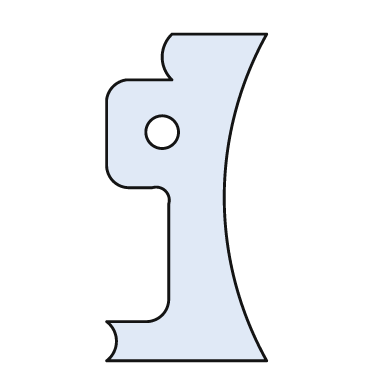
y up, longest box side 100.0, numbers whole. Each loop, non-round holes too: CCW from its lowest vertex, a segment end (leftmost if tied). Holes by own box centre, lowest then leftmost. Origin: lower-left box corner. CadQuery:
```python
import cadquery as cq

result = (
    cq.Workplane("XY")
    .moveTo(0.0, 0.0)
    .lineTo(49.0, 0.0)
    .threePointArc((36.0, 50.0), (49.0, 100.0))
    .lineTo(20.0, 100.0)
    .threePointArc((17.0, 93.0), (20.0, 86.0))
    .lineTo(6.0, 86.0)
    .threePointArc((2.0, 84.0), (0.0, 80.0))
    .lineTo(0.0, 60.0)
    .threePointArc((2.0, 55.0), (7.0, 53.0))
    .lineTo(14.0, 53.0)
    .threePointArc((18.0, 52.0), (19.0, 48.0))
    .lineTo(19.0, 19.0)
    .threePointArc((17.0, 14.0), (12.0, 12.0))
    .lineTo(0.0, 12.0)
    .threePointArc((3.0, 6.0), (0.0, 0.0))
    .close()
    .moveTo(17.0, 70.0)
    .circle(5.0)
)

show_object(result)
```